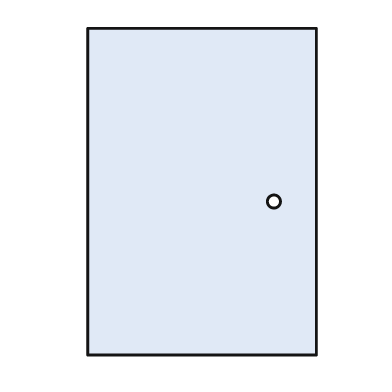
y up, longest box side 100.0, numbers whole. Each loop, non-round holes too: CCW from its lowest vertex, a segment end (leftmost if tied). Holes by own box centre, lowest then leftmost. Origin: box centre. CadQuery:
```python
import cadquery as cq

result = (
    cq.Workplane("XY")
    .moveTo(-35.0, -50.0)
    .lineTo(35.0, -50.0)
    .lineTo(35.0, 50.0)
    .lineTo(-35.0, 50.0)
    .close()
    .moveTo(22.0, -3.0)
    .circle(2.0)
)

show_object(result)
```